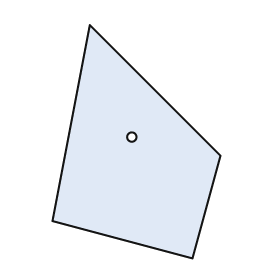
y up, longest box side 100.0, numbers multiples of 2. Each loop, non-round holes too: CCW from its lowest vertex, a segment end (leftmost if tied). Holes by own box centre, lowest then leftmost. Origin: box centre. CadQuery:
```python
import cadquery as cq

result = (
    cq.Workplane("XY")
    .moveTo(24.0, -50.0)
    .lineTo(36.0, -6.0)
    .lineTo(-20.0, 50.0)
    .lineTo(-36.0, -34.0)
    .close()
    .moveTo(-2.0, 2.0)
    .circle(2.0)
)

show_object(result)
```